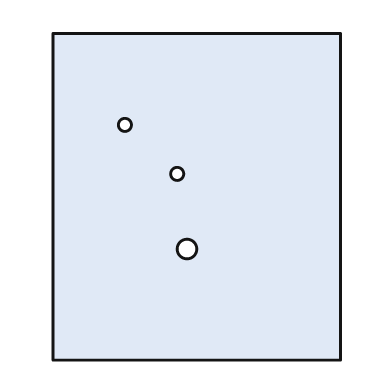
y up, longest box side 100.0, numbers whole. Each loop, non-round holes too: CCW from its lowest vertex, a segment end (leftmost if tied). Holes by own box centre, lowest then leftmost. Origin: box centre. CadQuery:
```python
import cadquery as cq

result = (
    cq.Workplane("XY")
    .moveTo(-44.0, -50.0)
    .lineTo(44.0, -50.0)
    .lineTo(44.0, 50.0)
    .lineTo(-44.0, 50.0)
    .close()
    .moveTo(-3.0, -16.0)
    .circle(3.0)
    .moveTo(-6.0, 7.0)
    .circle(2.0)
    .moveTo(-22.0, 22.0)
    .circle(2.0)
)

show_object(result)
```